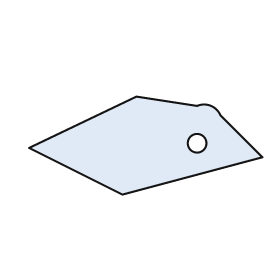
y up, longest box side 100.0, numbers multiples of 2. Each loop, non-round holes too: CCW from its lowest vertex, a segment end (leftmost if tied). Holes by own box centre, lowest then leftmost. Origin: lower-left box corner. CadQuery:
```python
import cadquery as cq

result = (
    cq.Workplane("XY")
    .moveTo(40.0, 0.0)
    .lineTo(100.0, 16.0)
    .lineTo(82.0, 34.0)
    .threePointArc((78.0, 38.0), (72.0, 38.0))
    .lineTo(46.0, 42.0)
    .lineTo(0.0, 20.0)
    .close()
    .moveTo(72.0, 22.0)
    .circle(4.0)
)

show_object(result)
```